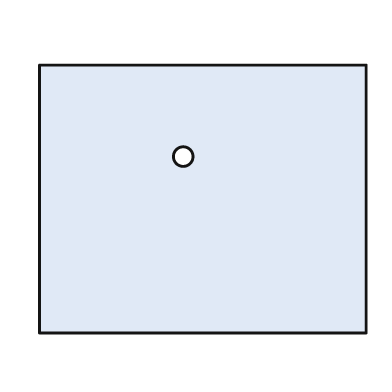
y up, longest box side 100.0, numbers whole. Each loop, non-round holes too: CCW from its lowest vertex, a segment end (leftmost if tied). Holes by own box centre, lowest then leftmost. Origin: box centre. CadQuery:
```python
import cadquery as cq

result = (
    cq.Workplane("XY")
    .moveTo(-50.0, -41.0)
    .lineTo(50.0, -41.0)
    .lineTo(50.0, 41.0)
    .lineTo(-50.0, 41.0)
    .close()
    .moveTo(-6.0, 13.0)
    .circle(3.0)
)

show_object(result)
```